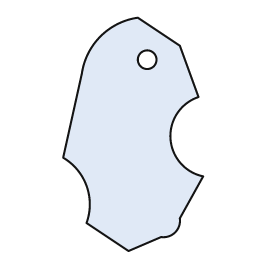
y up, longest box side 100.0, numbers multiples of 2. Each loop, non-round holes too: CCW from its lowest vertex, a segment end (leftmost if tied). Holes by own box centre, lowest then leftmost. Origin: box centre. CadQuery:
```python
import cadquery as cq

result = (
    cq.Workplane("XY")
    .moveTo(-2.0, -50.0)
    .lineTo(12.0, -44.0)
    .threePointArc((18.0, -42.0), (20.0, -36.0))
    .lineTo(30.0, -18.0)
    .threePointArc((16.0, -2.0), (28.0, 16.0))
    .lineTo(20.0, 38.0)
    .lineTo(2.0, 50.0)
    .threePointArc((-14.0, 42.0), (-22.0, 26.0))
    .lineTo(-30.0, -10.0)
    .threePointArc((-20.0, -22.0), (-20.0, -38.0))
    .close()
    .moveTo(6.0, 32.0)
    .circle(4.0)
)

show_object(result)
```